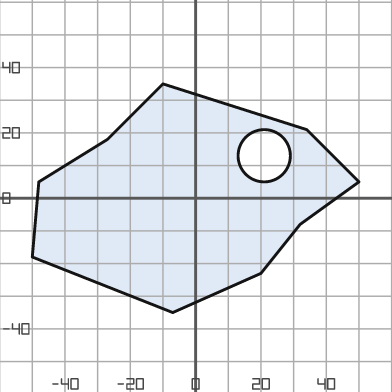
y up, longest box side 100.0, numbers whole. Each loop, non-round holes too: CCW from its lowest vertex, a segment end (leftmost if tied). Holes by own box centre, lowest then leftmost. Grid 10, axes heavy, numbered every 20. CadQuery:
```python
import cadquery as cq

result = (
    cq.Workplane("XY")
    .moveTo(-7.0, -35.0)
    .lineTo(20.0, -23.0)
    .lineTo(32.0, -8.0)
    .lineTo(50.0, 5.0)
    .lineTo(34.0, 21.0)
    .lineTo(-10.0, 35.0)
    .lineTo(-27.0, 18.0)
    .lineTo(-48.0, 5.0)
    .lineTo(-50.0, -18.0)
    .close()
    .moveTo(21.0, 13.0)
    .circle(8.0)
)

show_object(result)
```